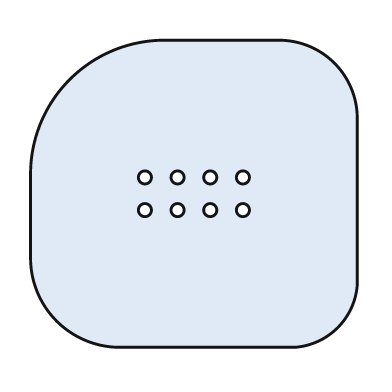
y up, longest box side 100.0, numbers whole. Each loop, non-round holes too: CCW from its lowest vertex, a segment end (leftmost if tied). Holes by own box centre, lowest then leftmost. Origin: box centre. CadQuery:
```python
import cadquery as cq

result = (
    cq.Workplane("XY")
    .moveTo(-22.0, -47.0)
    .lineTo(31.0, -47.0)
    .threePointArc((44.0, -41.0), (50.0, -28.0))
    .lineTo(50.0, 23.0)
    .threePointArc((43.0, 40.0), (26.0, 47.0))
    .lineTo(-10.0, 47.0)
    .threePointArc((-38.0, 35.0), (-50.0, 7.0))
    .lineTo(-50.0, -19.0)
    .threePointArc((-42.0, -39.0), (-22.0, -47.0))
    .close()
    .moveTo(-15.0, -5.0)
    .circle(2.0)
    .moveTo(-5.0, -5.0)
    .circle(2.0)
    .moveTo(5.0, -5.0)
    .circle(2.0)
    .moveTo(15.0, -5.0)
    .circle(2.0)
    .moveTo(-15.0, 5.0)
    .circle(2.0)
    .moveTo(-5.0, 5.0)
    .circle(2.0)
    .moveTo(5.0, 5.0)
    .circle(2.0)
    .moveTo(15.0, 5.0)
    .circle(2.0)
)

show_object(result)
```